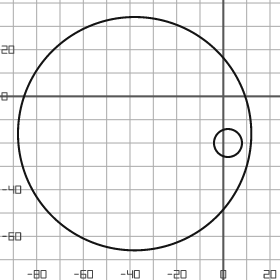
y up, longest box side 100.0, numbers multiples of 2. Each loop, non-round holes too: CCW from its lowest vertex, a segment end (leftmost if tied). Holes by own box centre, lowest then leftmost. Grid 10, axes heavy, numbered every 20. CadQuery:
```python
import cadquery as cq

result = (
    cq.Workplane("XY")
    .moveTo(-38.0, -16.0)
    .circle(50.0)
    .moveTo(2.0, -20.0)
    .circle(6.0)
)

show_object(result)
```